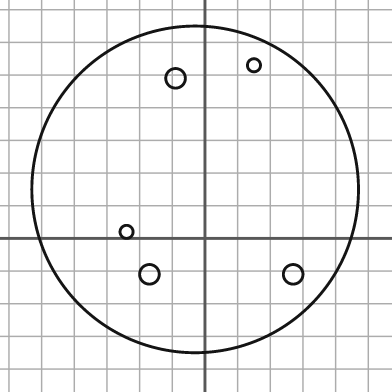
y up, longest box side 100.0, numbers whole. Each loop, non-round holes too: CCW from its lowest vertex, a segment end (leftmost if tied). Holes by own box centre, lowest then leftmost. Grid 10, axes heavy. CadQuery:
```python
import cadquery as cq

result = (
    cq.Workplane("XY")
    .moveTo(-3.0, 15.0)
    .circle(50.0)
    .moveTo(-17.0, -11.0)
    .circle(3.0)
    .moveTo(27.0, -11.0)
    .circle(3.0)
    .moveTo(-24.0, 2.0)
    .circle(2.0)
    .moveTo(-9.0, 49.0)
    .circle(3.0)
    .moveTo(15.0, 53.0)
    .circle(2.0)
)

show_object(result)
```